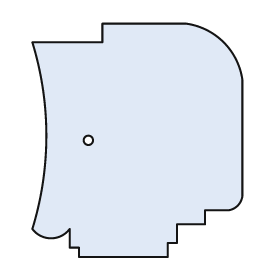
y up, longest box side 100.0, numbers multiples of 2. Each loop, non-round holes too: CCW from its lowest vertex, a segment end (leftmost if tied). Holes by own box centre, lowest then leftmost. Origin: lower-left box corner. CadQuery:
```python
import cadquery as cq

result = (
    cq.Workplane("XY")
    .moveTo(20.0, 0.0)
    .lineTo(58.0, 0.0)
    .lineTo(58.0, 6.0)
    .lineTo(62.0, 6.0)
    .lineTo(62.0, 14.0)
    .lineTo(74.0, 14.0)
    .lineTo(74.0, 20.0)
    .lineTo(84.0, 20.0)
    .threePointArc((88.0, 22.0), (90.0, 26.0))
    .lineTo(90.0, 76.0)
    .threePointArc((82.0, 92.0), (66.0, 100.0))
    .lineTo(30.0, 100.0)
    .lineTo(30.0, 92.0)
    .lineTo(0.0, 92.0)
    .threePointArc((6.0, 52.0), (0.0, 12.0))
    .threePointArc((8.0, 8.0), (16.0, 12.0))
    .lineTo(16.0, 4.0)
    .lineTo(20.0, 4.0)
    .close()
    .moveTo(24.0, 50.0)
    .circle(2.0)
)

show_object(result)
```